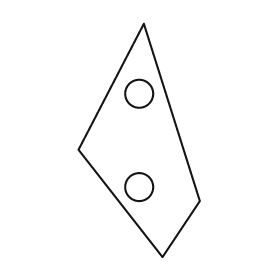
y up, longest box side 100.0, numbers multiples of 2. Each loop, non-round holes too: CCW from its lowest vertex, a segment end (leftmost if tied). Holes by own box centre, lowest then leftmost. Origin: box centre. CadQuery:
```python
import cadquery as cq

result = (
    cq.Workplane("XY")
    .moveTo(10.0, -50.0)
    .lineTo(26.0, -26.0)
    .lineTo(2.0, 50.0)
    .lineTo(-26.0, -4.0)
    .close()
    .moveTo(0.0, -20.0)
    .circle(6.0)
    .moveTo(0.0, 20.0)
    .circle(6.0)
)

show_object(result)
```